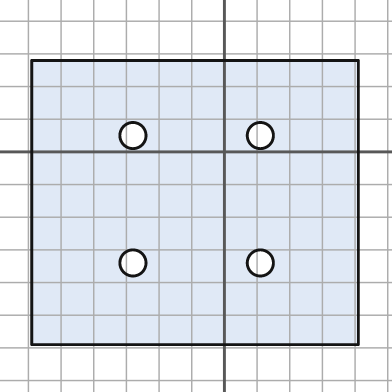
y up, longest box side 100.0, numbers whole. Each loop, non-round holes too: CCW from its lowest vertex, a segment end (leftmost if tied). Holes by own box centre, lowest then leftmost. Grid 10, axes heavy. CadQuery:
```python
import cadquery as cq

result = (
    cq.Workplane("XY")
    .moveTo(-59.0, -59.0)
    .lineTo(41.0, -59.0)
    .lineTo(41.0, 28.0)
    .lineTo(-59.0, 28.0)
    .close()
    .moveTo(-28.0, -34.0)
    .circle(4.0)
    .moveTo(11.0, -34.0)
    .circle(4.0)
    .moveTo(-28.0, 5.0)
    .circle(4.0)
    .moveTo(11.0, 5.0)
    .circle(4.0)
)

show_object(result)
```